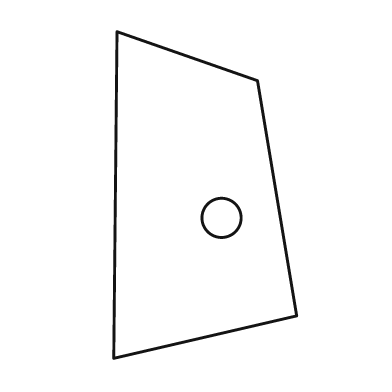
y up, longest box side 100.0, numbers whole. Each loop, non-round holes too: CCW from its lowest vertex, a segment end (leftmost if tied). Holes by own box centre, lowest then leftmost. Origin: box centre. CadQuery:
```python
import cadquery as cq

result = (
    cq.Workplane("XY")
    .moveTo(-28.0, -50.0)
    .lineTo(28.0, -37.0)
    .lineTo(16.0, 35.0)
    .lineTo(-27.0, 50.0)
    .close()
    .moveTo(5.0, -7.0)
    .circle(6.0)
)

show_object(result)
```